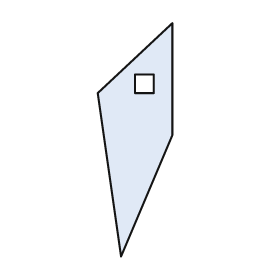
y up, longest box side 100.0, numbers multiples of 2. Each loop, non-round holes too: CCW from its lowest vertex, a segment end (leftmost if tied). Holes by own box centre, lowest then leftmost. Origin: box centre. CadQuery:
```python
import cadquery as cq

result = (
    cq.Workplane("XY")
    .moveTo(-6.0, -50.0)
    .lineTo(16.0, 2.0)
    .lineTo(16.0, 50.0)
    .lineTo(-16.0, 20.0)
    .close()
    .moveTo(0.0, 20.0)
    .lineTo(8.0, 20.0)
    .lineTo(8.0, 28.0)
    .lineTo(0.0, 28.0)
    .close()
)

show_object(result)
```